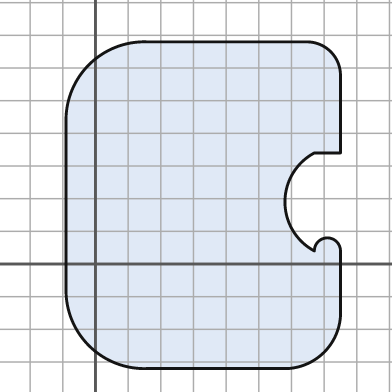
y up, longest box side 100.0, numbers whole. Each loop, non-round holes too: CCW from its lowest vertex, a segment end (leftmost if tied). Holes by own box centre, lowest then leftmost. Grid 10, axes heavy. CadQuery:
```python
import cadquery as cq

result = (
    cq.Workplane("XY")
    .moveTo(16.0, -32.0)
    .lineTo(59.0, -32.0)
    .threePointArc((70.0, -27.0), (75.0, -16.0))
    .lineTo(75.0, 4.0)
    .threePointArc((71.0, 8.0), (67.0, 4.0))
    .threePointArc((58.0, 19.0), (67.0, 34.0))
    .lineTo(75.0, 34.0)
    .lineTo(75.0, 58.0)
    .threePointArc((72.0, 65.0), (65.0, 68.0))
    .lineTo(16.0, 68.0)
    .threePointArc((-2.0, 61.0), (-9.0, 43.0))
    .lineTo(-9.0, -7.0)
    .threePointArc((-2.0, -25.0), (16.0, -32.0))
    .close()
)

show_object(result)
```